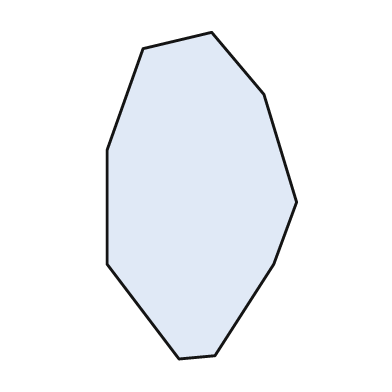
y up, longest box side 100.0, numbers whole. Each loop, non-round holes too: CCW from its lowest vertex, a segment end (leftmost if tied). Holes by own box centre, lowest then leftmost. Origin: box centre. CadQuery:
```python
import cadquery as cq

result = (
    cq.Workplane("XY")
    .moveTo(-7.0, -50.0)
    .lineTo(4.0, -49.0)
    .lineTo(22.0, -21.0)
    .lineTo(29.0, -2.0)
    .lineTo(19.0, 31.0)
    .lineTo(3.0, 50.0)
    .lineTo(-18.0, 45.0)
    .lineTo(-29.0, 14.0)
    .lineTo(-29.0, -21.0)
    .close()
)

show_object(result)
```